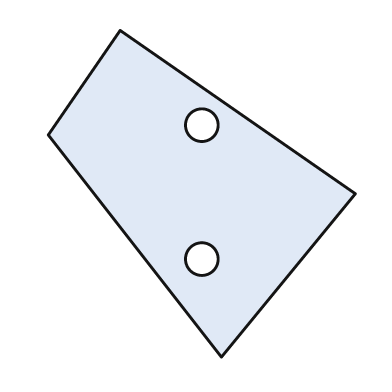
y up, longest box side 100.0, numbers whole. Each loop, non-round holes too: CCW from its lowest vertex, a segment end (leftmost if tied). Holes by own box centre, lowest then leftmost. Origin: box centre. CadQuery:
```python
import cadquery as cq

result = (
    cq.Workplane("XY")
    .moveTo(6.0, -50.0)
    .lineTo(47.0, 0.0)
    .lineTo(-25.0, 50.0)
    .lineTo(-47.0, 18.0)
    .close()
    .moveTo(0.0, -20.0)
    .circle(5.0)
    .moveTo(0.0, 21.0)
    .circle(5.0)
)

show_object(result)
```